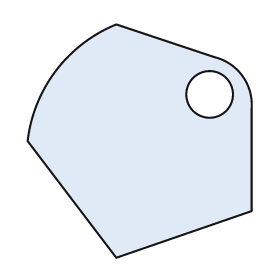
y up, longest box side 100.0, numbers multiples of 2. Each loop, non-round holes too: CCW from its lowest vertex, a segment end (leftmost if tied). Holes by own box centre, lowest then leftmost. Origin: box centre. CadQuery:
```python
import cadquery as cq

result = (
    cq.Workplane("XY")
    .moveTo(-10.0, -50.0)
    .lineTo(48.0, -30.0)
    .lineTo(48.0, 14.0)
    .threePointArc((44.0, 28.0), (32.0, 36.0))
    .lineTo(-10.0, 50.0)
    .threePointArc((-36.0, 30.0), (-48.0, 0.0))
    .close()
    .moveTo(30.0, 20.0)
    .circle(10.0)
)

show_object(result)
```